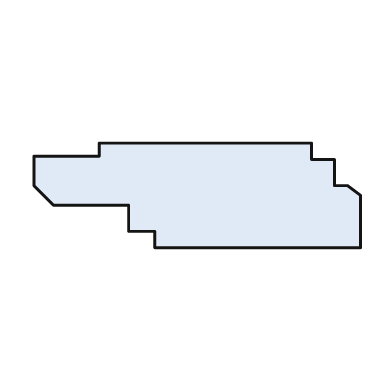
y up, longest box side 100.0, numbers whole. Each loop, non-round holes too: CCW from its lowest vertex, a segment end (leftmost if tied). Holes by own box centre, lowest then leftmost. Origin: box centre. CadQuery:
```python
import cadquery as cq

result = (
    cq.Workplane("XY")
    .moveTo(-13.0, -16.0)
    .lineTo(50.0, -16.0)
    .lineTo(50.0, 0.0)
    .lineTo(46.0, 3.0)
    .lineTo(42.0, 3.0)
    .lineTo(42.0, 11.0)
    .lineTo(35.0, 11.0)
    .lineTo(35.0, 16.0)
    .lineTo(-30.0, 16.0)
    .lineTo(-30.0, 12.0)
    .lineTo(-50.0, 12.0)
    .lineTo(-50.0, 3.0)
    .lineTo(-44.0, -3.0)
    .lineTo(-21.0, -3.0)
    .lineTo(-21.0, -11.0)
    .lineTo(-13.0, -11.0)
    .close()
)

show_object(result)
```